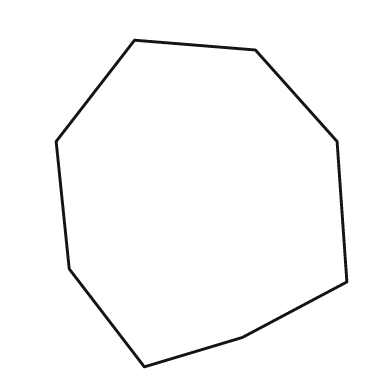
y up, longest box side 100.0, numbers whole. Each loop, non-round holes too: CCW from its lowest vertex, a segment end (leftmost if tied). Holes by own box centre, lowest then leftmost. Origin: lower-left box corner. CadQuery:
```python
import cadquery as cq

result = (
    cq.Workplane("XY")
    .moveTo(27.0, 0.0)
    .lineTo(57.0, 9.0)
    .lineTo(89.0, 26.0)
    .lineTo(86.0, 69.0)
    .lineTo(61.0, 97.0)
    .lineTo(24.0, 100.0)
    .lineTo(0.0, 69.0)
    .lineTo(4.0, 30.0)
    .close()
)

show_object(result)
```